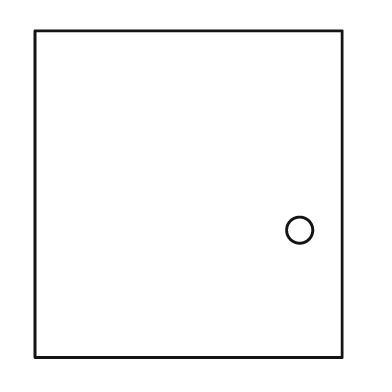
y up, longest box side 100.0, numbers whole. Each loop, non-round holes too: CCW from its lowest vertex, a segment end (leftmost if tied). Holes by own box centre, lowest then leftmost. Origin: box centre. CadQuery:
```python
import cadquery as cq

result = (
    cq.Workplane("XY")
    .moveTo(-47.0, -50.0)
    .lineTo(47.0, -50.0)
    .lineTo(47.0, 50.0)
    .lineTo(-47.0, 50.0)
    .close()
    .moveTo(34.0, -11.0)
    .circle(4.0)
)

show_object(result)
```